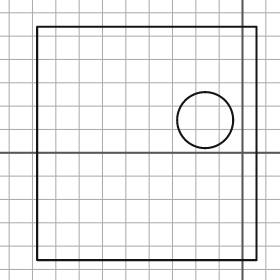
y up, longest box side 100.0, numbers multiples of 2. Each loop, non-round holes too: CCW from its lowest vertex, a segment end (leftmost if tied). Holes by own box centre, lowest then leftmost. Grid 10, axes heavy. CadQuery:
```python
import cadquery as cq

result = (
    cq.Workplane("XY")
    .moveTo(-88.0, -46.0)
    .lineTo(6.0, -46.0)
    .lineTo(6.0, 54.0)
    .lineTo(-88.0, 54.0)
    .close()
    .moveTo(-16.0, 14.0)
    .circle(12.0)
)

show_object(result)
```